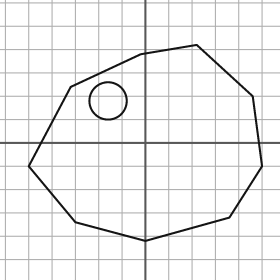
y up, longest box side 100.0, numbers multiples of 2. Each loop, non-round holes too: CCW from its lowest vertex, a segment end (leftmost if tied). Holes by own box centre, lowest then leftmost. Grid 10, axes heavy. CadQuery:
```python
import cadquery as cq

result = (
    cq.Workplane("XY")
    .moveTo(0.0, -42.0)
    .lineTo(36.0, -32.0)
    .lineTo(50.0, -10.0)
    .lineTo(46.0, 20.0)
    .lineTo(22.0, 42.0)
    .lineTo(-2.0, 38.0)
    .lineTo(-32.0, 24.0)
    .lineTo(-50.0, -10.0)
    .lineTo(-30.0, -34.0)
    .close()
    .moveTo(-16.0, 18.0)
    .circle(8.0)
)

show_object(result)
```